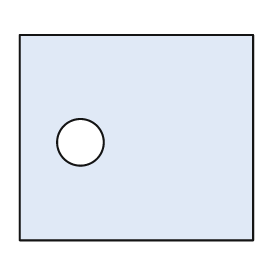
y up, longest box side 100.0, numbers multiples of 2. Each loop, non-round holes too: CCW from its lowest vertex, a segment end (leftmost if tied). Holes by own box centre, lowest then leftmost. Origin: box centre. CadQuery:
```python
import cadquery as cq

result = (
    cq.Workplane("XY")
    .moveTo(-50.0, -44.0)
    .lineTo(50.0, -44.0)
    .lineTo(50.0, 44.0)
    .lineTo(-50.0, 44.0)
    .close()
    .moveTo(-24.0, -2.0)
    .circle(10.0)
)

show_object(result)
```